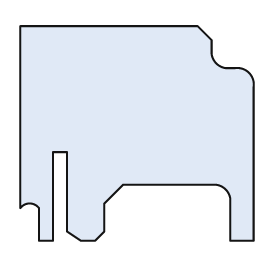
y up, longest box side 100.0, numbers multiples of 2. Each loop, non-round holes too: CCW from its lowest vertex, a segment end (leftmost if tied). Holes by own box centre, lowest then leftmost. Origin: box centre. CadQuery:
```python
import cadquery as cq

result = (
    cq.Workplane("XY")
    .moveTo(-42.0, -46.0)
    .lineTo(-36.0, -46.0)
    .lineTo(-36.0, -8.0)
    .lineTo(-30.0, -8.0)
    .lineTo(-30.0, -42.0)
    .lineTo(-24.0, -46.0)
    .lineTo(-18.0, -46.0)
    .lineTo(-14.0, -42.0)
    .lineTo(-14.0, -30.0)
    .lineTo(-6.0, -22.0)
    .lineTo(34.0, -22.0)
    .threePointArc((38.0, -24.0), (40.0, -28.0))
    .lineTo(40.0, -46.0)
    .lineTo(50.0, -46.0)
    .lineTo(50.0, 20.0)
    .threePointArc((48.0, 26.0), (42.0, 28.0))
    .lineTo(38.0, 28.0)
    .threePointArc((34.0, 30.0), (32.0, 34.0))
    .lineTo(32.0, 40.0)
    .lineTo(26.0, 46.0)
    .lineTo(-50.0, 46.0)
    .lineTo(-50.0, -32.0)
    .threePointArc((-46.0, -30.0), (-42.0, -32.0))
    .close()
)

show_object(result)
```